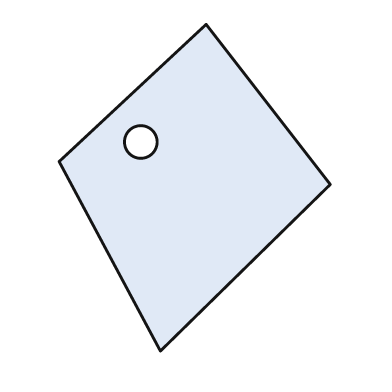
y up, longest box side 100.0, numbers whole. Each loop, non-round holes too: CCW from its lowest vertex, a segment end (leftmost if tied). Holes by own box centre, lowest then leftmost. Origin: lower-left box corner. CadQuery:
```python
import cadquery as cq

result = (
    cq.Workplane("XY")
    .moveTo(31.0, 0.0)
    .lineTo(83.0, 51.0)
    .lineTo(45.0, 100.0)
    .lineTo(0.0, 58.0)
    .close()
    .moveTo(25.0, 64.0)
    .circle(5.0)
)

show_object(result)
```